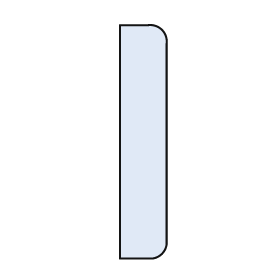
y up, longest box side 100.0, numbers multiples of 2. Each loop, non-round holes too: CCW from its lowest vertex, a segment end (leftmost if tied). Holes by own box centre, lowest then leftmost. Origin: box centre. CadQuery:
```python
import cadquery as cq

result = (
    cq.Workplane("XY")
    .moveTo(-10.0, -50.0)
    .lineTo(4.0, -50.0)
    .threePointArc((8.0, -48.0), (10.0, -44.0))
    .lineTo(10.0, 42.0)
    .threePointArc((8.0, 48.0), (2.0, 50.0))
    .lineTo(-10.0, 50.0)
    .close()
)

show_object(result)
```